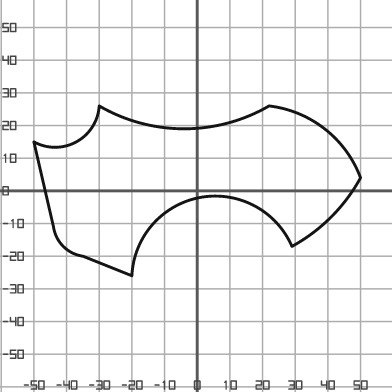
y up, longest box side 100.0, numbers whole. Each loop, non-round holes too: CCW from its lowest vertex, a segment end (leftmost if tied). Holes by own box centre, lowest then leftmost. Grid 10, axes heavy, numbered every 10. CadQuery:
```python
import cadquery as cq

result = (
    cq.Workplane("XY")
    .moveTo(-20.0, -26.0)
    .threePointArc((1.0, -2.0), (29.0, -17.0))
    .threePointArc((41.0, -8.0), (50.0, 4.0))
    .threePointArc((39.0, 19.0), (22.0, 26.0))
    .threePointArc((-4.0, 19.0), (-30.0, 26.0))
    .threePointArc((-37.0, 15.0), (-50.0, 15.0))
    .lineTo(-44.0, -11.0)
    .threePointArc((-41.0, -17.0), (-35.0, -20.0))
    .close()
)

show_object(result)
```